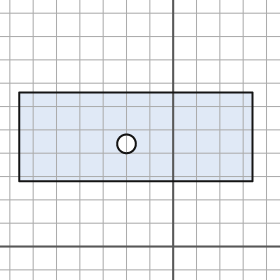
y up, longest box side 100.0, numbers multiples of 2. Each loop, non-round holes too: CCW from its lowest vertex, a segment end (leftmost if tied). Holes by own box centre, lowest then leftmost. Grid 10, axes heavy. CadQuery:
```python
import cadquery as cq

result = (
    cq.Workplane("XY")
    .moveTo(-66.0, 28.0)
    .lineTo(34.0, 28.0)
    .lineTo(34.0, 66.0)
    .lineTo(-66.0, 66.0)
    .close()
    .moveTo(-20.0, 44.0)
    .circle(4.0)
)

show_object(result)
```